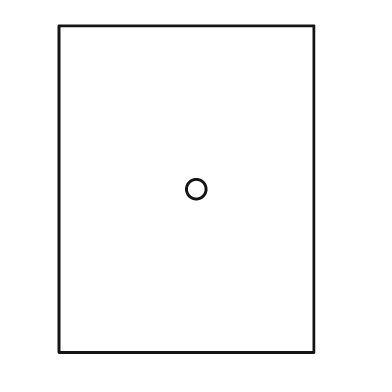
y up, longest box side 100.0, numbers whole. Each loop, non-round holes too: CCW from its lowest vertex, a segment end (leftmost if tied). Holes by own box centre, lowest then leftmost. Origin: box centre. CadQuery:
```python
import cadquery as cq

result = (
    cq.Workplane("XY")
    .moveTo(-39.0, -50.0)
    .lineTo(39.0, -50.0)
    .lineTo(39.0, 50.0)
    .lineTo(-39.0, 50.0)
    .close()
    .moveTo(3.0, 0.0)
    .circle(3.0)
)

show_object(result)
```